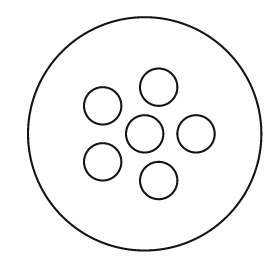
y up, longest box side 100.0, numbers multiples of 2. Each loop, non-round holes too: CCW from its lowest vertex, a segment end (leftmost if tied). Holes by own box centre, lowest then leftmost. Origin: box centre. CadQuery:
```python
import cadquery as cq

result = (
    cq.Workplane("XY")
    .moveTo(0.0, 0.0)
    .circle(50.0)
    .moveTo(6.0, -20.0)
    .circle(8.0)
    .moveTo(-18.0, -12.0)
    .circle(8.0)
    .moveTo(0.0, 0.0)
    .circle(8.0)
    .moveTo(22.0, 0.0)
    .circle(8.0)
    .moveTo(-18.0, 12.0)
    .circle(8.0)
    .moveTo(6.0, 20.0)
    .circle(8.0)
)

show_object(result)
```